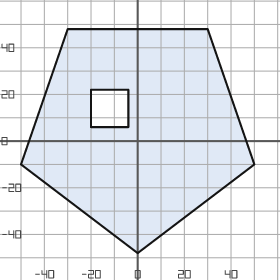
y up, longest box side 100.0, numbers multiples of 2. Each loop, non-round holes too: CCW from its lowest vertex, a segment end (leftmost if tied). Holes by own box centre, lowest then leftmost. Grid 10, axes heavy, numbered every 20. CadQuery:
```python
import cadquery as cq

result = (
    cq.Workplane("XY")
    .moveTo(0.0, -48.0)
    .lineTo(50.0, -10.0)
    .lineTo(30.0, 48.0)
    .lineTo(-30.0, 48.0)
    .lineTo(-50.0, -10.0)
    .close()
    .moveTo(-20.0, 6.0)
    .lineTo(-4.0, 6.0)
    .lineTo(-4.0, 22.0)
    .lineTo(-20.0, 22.0)
    .close()
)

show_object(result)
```